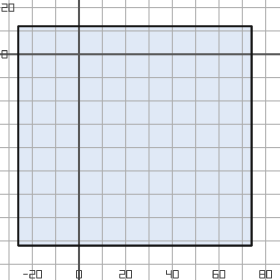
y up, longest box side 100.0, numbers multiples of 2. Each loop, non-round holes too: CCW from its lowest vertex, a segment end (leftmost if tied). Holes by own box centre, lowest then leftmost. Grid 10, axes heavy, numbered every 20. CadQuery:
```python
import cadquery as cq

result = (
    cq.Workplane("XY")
    .moveTo(-26.0, -82.0)
    .lineTo(74.0, -82.0)
    .lineTo(74.0, 12.0)
    .lineTo(-26.0, 12.0)
    .close()
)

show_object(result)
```